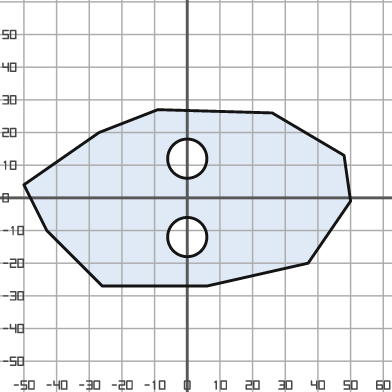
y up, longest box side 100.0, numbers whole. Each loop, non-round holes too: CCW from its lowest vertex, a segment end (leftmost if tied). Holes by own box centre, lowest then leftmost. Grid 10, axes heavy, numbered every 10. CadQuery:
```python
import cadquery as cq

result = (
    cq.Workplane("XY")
    .moveTo(-26.0, -27.0)
    .lineTo(6.0, -27.0)
    .lineTo(37.0, -20.0)
    .lineTo(50.0, -1.0)
    .lineTo(48.0, 13.0)
    .lineTo(26.0, 26.0)
    .lineTo(-9.0, 27.0)
    .lineTo(-27.0, 20.0)
    .lineTo(-50.0, 4.0)
    .lineTo(-43.0, -10.0)
    .close()
    .moveTo(0.0, -12.0)
    .circle(6.0)
    .moveTo(0.0, 12.0)
    .circle(6.0)
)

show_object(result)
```